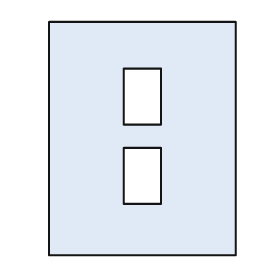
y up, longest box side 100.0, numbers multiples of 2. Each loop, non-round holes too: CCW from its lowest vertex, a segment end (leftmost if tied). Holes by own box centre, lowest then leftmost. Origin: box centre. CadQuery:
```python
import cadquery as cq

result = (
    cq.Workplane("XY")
    .moveTo(-40.0, -50.0)
    .lineTo(40.0, -50.0)
    .lineTo(40.0, 50.0)
    .lineTo(-40.0, 50.0)
    .close()
    .moveTo(-8.0, -28.0)
    .lineTo(8.0, -28.0)
    .lineTo(8.0, -4.0)
    .lineTo(-8.0, -4.0)
    .close()
    .moveTo(-8.0, 6.0)
    .lineTo(8.0, 6.0)
    .lineTo(8.0, 30.0)
    .lineTo(-8.0, 30.0)
    .close()
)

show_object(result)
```